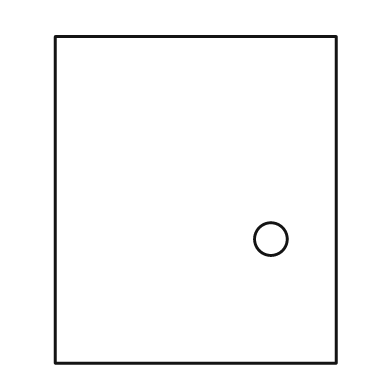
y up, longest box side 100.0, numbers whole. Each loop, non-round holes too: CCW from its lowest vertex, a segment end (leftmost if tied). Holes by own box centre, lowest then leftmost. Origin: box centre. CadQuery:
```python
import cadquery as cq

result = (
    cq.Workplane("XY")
    .moveTo(-43.0, -50.0)
    .lineTo(43.0, -50.0)
    .lineTo(43.0, 50.0)
    .lineTo(-43.0, 50.0)
    .close()
    .moveTo(23.0, -12.0)
    .circle(5.0)
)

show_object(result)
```